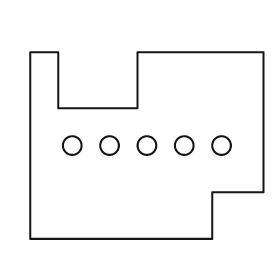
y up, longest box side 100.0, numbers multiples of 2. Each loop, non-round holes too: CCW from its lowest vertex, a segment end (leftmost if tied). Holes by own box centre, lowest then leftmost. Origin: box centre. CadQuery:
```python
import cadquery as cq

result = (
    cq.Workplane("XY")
    .moveTo(-50.0, -40.0)
    .lineTo(28.0, -40.0)
    .lineTo(28.0, -20.0)
    .lineTo(50.0, -20.0)
    .lineTo(50.0, 40.0)
    .lineTo(-4.0, 40.0)
    .lineTo(-4.0, 16.0)
    .lineTo(-38.0, 16.0)
    .lineTo(-38.0, 40.0)
    .lineTo(-50.0, 40.0)
    .close()
    .moveTo(-32.0, 0.0)
    .circle(4.0)
    .moveTo(-16.0, 0.0)
    .circle(4.0)
    .moveTo(0.0, 0.0)
    .circle(4.0)
    .moveTo(16.0, 0.0)
    .circle(4.0)
    .moveTo(32.0, 0.0)
    .circle(4.0)
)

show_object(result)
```